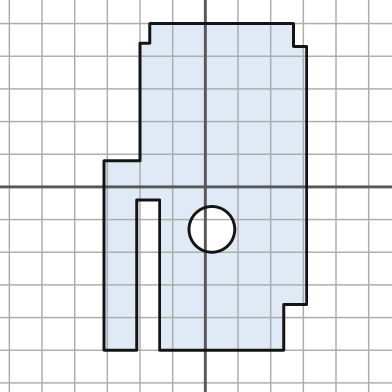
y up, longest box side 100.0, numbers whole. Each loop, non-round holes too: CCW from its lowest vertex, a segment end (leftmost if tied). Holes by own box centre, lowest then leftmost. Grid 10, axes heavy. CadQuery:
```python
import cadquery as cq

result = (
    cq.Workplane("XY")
    .moveTo(-31.0, -50.0)
    .lineTo(-21.0, -50.0)
    .lineTo(-21.0, -4.0)
    .lineTo(-14.0, -4.0)
    .lineTo(-14.0, -50.0)
    .lineTo(24.0, -50.0)
    .lineTo(24.0, -36.0)
    .lineTo(31.0, -36.0)
    .lineTo(31.0, 43.0)
    .lineTo(27.0, 43.0)
    .lineTo(27.0, 50.0)
    .lineTo(-17.0, 50.0)
    .lineTo(-17.0, 44.0)
    .lineTo(-20.0, 44.0)
    .lineTo(-20.0, 8.0)
    .lineTo(-31.0, 8.0)
    .close()
    .moveTo(2.0, -13.0)
    .circle(7.0)
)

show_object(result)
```